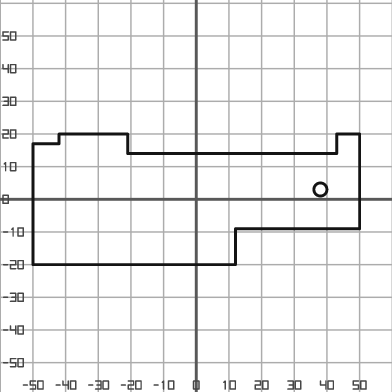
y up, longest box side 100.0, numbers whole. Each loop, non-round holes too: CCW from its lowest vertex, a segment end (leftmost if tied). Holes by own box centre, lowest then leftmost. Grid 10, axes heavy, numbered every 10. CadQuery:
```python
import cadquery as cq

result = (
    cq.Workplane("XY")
    .moveTo(-50.0, -20.0)
    .lineTo(12.0, -20.0)
    .lineTo(12.0, -9.0)
    .lineTo(50.0, -9.0)
    .lineTo(50.0, 20.0)
    .lineTo(43.0, 20.0)
    .lineTo(43.0, 14.0)
    .lineTo(-21.0, 14.0)
    .lineTo(-21.0, 20.0)
    .lineTo(-42.0, 20.0)
    .lineTo(-42.0, 17.0)
    .lineTo(-50.0, 17.0)
    .close()
    .moveTo(38.0, 3.0)
    .circle(2.0)
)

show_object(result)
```